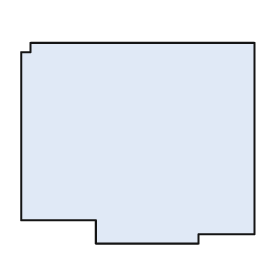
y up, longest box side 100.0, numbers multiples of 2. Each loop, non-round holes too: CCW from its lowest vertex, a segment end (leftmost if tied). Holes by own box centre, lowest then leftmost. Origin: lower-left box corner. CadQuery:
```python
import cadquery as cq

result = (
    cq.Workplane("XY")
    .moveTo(32.0, 0.0)
    .lineTo(76.0, 0.0)
    .lineTo(76.0, 4.0)
    .lineTo(100.0, 4.0)
    .lineTo(100.0, 86.0)
    .lineTo(4.0, 86.0)
    .lineTo(4.0, 82.0)
    .lineTo(0.0, 82.0)
    .lineTo(0.0, 10.0)
    .lineTo(32.0, 10.0)
    .close()
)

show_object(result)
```